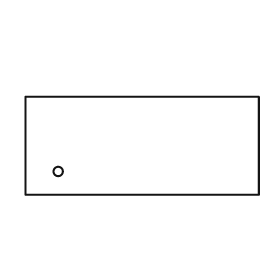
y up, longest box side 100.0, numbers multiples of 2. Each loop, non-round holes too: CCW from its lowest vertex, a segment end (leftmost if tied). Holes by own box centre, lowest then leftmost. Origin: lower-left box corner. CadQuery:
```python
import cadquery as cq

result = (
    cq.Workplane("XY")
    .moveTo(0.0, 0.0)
    .lineTo(100.0, 0.0)
    .lineTo(100.0, 42.0)
    .lineTo(0.0, 42.0)
    .close()
    .moveTo(14.0, 10.0)
    .circle(2.0)
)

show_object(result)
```